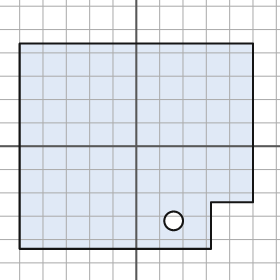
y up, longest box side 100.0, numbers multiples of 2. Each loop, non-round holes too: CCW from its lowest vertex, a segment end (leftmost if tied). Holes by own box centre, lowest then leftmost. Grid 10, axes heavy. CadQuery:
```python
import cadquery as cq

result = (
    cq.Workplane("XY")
    .moveTo(-50.0, -44.0)
    .lineTo(32.0, -44.0)
    .lineTo(32.0, -24.0)
    .lineTo(50.0, -24.0)
    .lineTo(50.0, 44.0)
    .lineTo(-50.0, 44.0)
    .close()
    .moveTo(16.0, -32.0)
    .circle(4.0)
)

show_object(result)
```